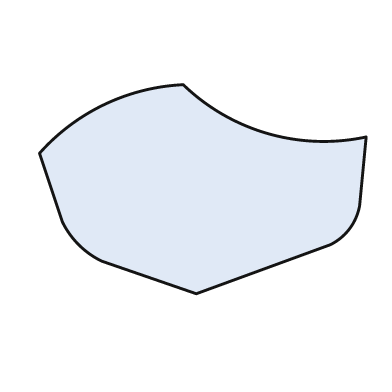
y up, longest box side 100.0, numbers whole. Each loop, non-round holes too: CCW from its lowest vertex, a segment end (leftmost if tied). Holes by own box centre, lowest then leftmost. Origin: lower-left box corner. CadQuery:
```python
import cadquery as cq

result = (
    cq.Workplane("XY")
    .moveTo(48.0, 0.0)
    .lineTo(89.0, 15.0)
    .threePointArc((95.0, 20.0), (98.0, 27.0))
    .lineTo(100.0, 48.0)
    .threePointArc((70.0, 49.0), (44.0, 64.0))
    .threePointArc((20.0, 58.0), (0.0, 43.0))
    .lineTo(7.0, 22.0)
    .threePointArc((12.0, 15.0), (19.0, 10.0))
    .close()
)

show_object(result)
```